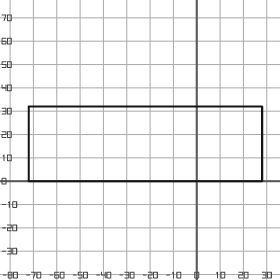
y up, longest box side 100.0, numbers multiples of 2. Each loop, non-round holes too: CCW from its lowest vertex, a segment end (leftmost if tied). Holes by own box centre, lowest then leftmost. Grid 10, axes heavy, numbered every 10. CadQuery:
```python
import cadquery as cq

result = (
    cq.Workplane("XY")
    .moveTo(-72.0, 0.0)
    .lineTo(28.0, 0.0)
    .lineTo(28.0, 32.0)
    .lineTo(-72.0, 32.0)
    .close()
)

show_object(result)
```